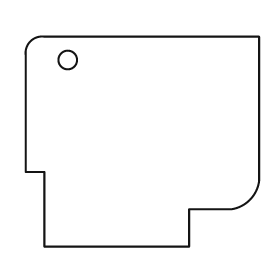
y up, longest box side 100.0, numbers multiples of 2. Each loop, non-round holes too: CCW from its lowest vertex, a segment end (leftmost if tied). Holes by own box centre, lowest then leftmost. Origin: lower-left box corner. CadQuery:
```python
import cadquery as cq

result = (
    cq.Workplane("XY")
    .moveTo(8.0, 0.0)
    .lineTo(70.0, 0.0)
    .lineTo(70.0, 16.0)
    .lineTo(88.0, 16.0)
    .threePointArc((96.0, 20.0), (100.0, 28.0))
    .lineTo(100.0, 90.0)
    .lineTo(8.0, 90.0)
    .threePointArc((2.0, 88.0), (0.0, 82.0))
    .lineTo(0.0, 32.0)
    .lineTo(8.0, 32.0)
    .close()
    .moveTo(18.0, 80.0)
    .circle(4.0)
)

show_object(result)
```